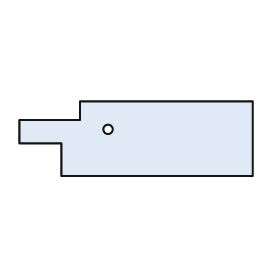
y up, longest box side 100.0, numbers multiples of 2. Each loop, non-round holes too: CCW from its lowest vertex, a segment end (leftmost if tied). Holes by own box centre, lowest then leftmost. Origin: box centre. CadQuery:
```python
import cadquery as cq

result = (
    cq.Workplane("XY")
    .moveTo(-32.0, -16.0)
    .lineTo(50.0, -16.0)
    .lineTo(50.0, 16.0)
    .lineTo(-24.0, 16.0)
    .lineTo(-24.0, 8.0)
    .lineTo(-50.0, 8.0)
    .lineTo(-50.0, -2.0)
    .lineTo(-32.0, -2.0)
    .close()
    .moveTo(-12.0, 4.0)
    .circle(2.0)
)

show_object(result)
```